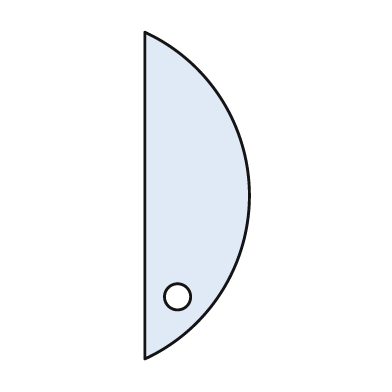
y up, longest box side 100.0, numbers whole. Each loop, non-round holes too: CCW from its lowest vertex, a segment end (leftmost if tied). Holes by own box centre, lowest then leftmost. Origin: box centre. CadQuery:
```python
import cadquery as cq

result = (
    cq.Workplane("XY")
    .moveTo(-16.0, -50.0)
    .threePointArc((16.0, 0.0), (-16.0, 50.0))
    .close()
    .moveTo(-6.0, -31.0)
    .circle(4.0)
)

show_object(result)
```